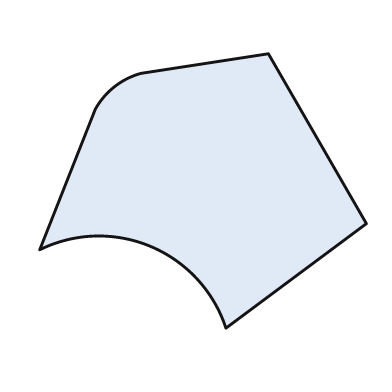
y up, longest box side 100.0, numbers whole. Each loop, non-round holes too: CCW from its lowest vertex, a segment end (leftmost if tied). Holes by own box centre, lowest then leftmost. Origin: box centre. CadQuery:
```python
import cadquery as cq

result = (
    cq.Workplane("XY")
    .moveTo(7.0, -42.0)
    .lineTo(50.0, -10.0)
    .lineTo(20.0, 42.0)
    .lineTo(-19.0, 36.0)
    .threePointArc((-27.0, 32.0), (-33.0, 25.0))
    .lineTo(-50.0, -18.0)
    .threePointArc((-16.0, -17.0), (7.0, -42.0))
    .close()
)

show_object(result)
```